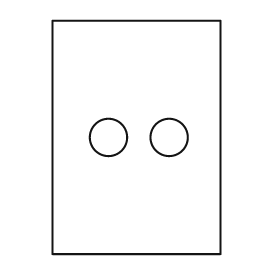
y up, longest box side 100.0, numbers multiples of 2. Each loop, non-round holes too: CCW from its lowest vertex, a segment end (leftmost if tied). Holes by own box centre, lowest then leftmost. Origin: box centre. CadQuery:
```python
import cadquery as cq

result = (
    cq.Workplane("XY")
    .moveTo(-36.0, -50.0)
    .lineTo(36.0, -50.0)
    .lineTo(36.0, 50.0)
    .lineTo(-36.0, 50.0)
    .close()
    .moveTo(-12.0, 0.0)
    .circle(8.0)
    .moveTo(14.0, 0.0)
    .circle(8.0)
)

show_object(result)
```